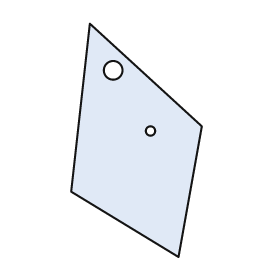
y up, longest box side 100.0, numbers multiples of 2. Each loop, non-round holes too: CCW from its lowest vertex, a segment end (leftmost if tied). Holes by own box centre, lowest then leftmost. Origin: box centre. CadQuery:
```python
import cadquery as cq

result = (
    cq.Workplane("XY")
    .moveTo(18.0, -50.0)
    .lineTo(28.0, 6.0)
    .lineTo(-20.0, 50.0)
    .lineTo(-28.0, -22.0)
    .close()
    .moveTo(6.0, 4.0)
    .circle(2.0)
    .moveTo(-10.0, 30.0)
    .circle(4.0)
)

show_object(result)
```